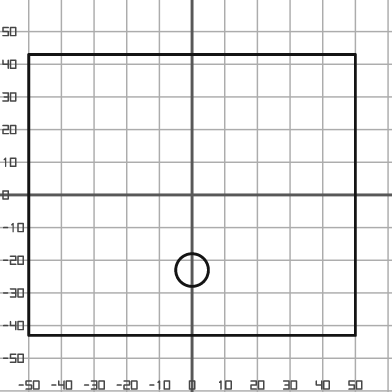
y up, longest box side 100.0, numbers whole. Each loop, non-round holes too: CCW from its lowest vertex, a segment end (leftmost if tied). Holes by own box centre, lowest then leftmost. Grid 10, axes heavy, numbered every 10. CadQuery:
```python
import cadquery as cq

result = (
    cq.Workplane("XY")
    .moveTo(-50.0, -43.0)
    .lineTo(50.0, -43.0)
    .lineTo(50.0, 43.0)
    .lineTo(-50.0, 43.0)
    .close()
    .moveTo(0.0, -23.0)
    .circle(5.0)
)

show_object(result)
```